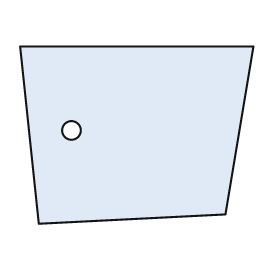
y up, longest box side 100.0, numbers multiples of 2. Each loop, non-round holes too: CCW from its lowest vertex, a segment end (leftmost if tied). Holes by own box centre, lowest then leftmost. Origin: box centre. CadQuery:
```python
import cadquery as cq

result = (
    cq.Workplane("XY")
    .moveTo(-42.0, -38.0)
    .lineTo(38.0, -34.0)
    .lineTo(50.0, 38.0)
    .lineTo(-50.0, 38.0)
    .close()
    .moveTo(-28.0, 2.0)
    .circle(4.0)
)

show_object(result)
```